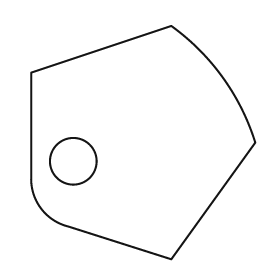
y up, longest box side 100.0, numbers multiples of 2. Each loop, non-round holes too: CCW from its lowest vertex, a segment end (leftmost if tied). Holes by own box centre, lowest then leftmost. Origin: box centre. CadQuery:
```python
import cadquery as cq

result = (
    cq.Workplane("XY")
    .moveTo(12.0, -50.0)
    .lineTo(48.0, 0.0)
    .threePointArc((34.0, 28.0), (12.0, 50.0))
    .lineTo(-48.0, 30.0)
    .lineTo(-48.0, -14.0)
    .threePointArc((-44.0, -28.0), (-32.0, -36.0))
    .close()
    .moveTo(-30.0, -8.0)
    .circle(10.0)
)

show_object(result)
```